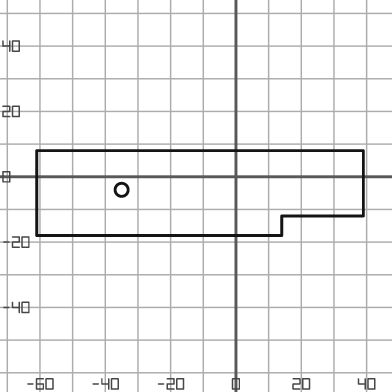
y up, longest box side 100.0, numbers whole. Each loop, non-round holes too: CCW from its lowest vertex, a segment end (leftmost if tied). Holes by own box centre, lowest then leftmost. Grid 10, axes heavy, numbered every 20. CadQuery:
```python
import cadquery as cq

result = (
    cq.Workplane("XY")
    .moveTo(-61.0, -18.0)
    .lineTo(14.0, -18.0)
    .lineTo(14.0, -12.0)
    .lineTo(39.0, -12.0)
    .lineTo(39.0, 8.0)
    .lineTo(-61.0, 8.0)
    .close()
    .moveTo(-35.0, -4.0)
    .circle(2.0)
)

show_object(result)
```